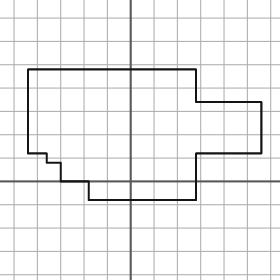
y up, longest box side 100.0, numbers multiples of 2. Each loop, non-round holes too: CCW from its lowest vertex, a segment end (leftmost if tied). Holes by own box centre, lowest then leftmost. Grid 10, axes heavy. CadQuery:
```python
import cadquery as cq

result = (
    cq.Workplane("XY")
    .moveTo(-18.0, -8.0)
    .lineTo(28.0, -8.0)
    .lineTo(28.0, 12.0)
    .lineTo(56.0, 12.0)
    .lineTo(56.0, 34.0)
    .lineTo(28.0, 34.0)
    .lineTo(28.0, 48.0)
    .lineTo(-44.0, 48.0)
    .lineTo(-44.0, 12.0)
    .lineTo(-36.0, 12.0)
    .lineTo(-36.0, 8.0)
    .lineTo(-30.0, 8.0)
    .lineTo(-30.0, 0.0)
    .lineTo(-18.0, 0.0)
    .close()
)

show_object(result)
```